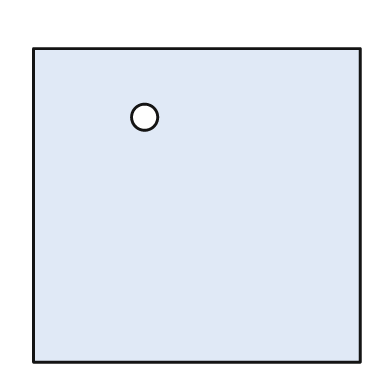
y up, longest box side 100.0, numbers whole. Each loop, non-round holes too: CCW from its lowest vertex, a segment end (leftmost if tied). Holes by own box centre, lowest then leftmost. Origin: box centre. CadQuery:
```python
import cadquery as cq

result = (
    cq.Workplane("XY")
    .moveTo(-50.0, -48.0)
    .lineTo(50.0, -48.0)
    .lineTo(50.0, 48.0)
    .lineTo(-50.0, 48.0)
    .close()
    .moveTo(-16.0, 27.0)
    .circle(4.0)
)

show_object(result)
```